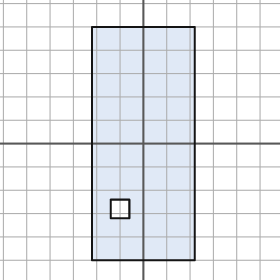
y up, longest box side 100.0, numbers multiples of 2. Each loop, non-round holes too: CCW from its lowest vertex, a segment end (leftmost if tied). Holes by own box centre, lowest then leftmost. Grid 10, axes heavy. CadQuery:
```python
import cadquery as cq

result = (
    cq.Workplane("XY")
    .moveTo(-22.0, -50.0)
    .lineTo(22.0, -50.0)
    .lineTo(22.0, 50.0)
    .lineTo(-22.0, 50.0)
    .close()
    .moveTo(-14.0, -32.0)
    .lineTo(-6.0, -32.0)
    .lineTo(-6.0, -24.0)
    .lineTo(-14.0, -24.0)
    .close()
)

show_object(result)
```